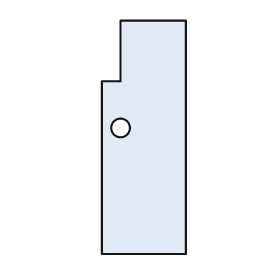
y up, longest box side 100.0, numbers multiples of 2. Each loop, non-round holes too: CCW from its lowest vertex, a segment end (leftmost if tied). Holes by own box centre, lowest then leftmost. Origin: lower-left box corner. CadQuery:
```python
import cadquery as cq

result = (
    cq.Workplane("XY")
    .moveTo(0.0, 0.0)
    .lineTo(36.0, 0.0)
    .lineTo(36.0, 100.0)
    .lineTo(8.0, 100.0)
    .lineTo(8.0, 74.0)
    .lineTo(0.0, 74.0)
    .close()
    .moveTo(8.0, 54.0)
    .circle(4.0)
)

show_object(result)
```